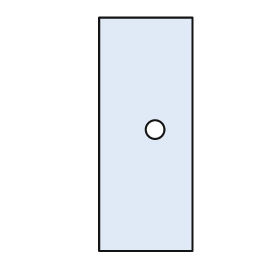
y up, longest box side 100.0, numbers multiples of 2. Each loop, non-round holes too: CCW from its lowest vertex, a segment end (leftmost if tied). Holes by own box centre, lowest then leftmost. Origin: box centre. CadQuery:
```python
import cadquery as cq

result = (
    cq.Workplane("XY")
    .moveTo(-20.0, -50.0)
    .lineTo(20.0, -50.0)
    .lineTo(20.0, 50.0)
    .lineTo(-20.0, 50.0)
    .close()
    .moveTo(4.0, 2.0)
    .circle(4.0)
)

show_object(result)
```